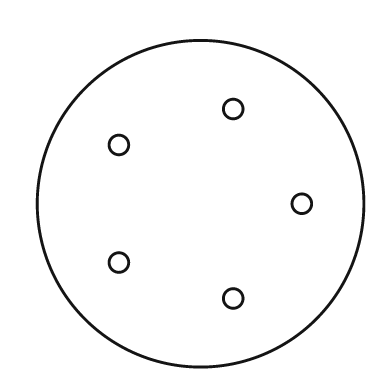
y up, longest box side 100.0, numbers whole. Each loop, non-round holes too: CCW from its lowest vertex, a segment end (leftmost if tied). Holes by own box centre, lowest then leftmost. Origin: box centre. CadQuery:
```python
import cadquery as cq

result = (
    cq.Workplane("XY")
    .moveTo(0.0, 0.0)
    .circle(50.0)
    .moveTo(10.0, -29.0)
    .circle(3.0)
    .moveTo(-25.0, -18.0)
    .circle(3.0)
    .moveTo(31.0, 0.0)
    .circle(3.0)
    .moveTo(-25.0, 18.0)
    .circle(3.0)
    .moveTo(10.0, 29.0)
    .circle(3.0)
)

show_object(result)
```